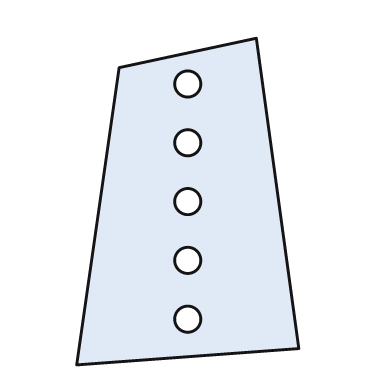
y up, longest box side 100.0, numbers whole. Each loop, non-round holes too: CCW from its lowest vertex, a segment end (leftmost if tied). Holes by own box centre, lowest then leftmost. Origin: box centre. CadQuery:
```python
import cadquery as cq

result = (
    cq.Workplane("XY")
    .moveTo(-34.0, -50.0)
    .lineTo(34.0, -45.0)
    .lineTo(21.0, 50.0)
    .lineTo(-21.0, 41.0)
    .close()
    .moveTo(0.0, -36.0)
    .circle(4.0)
    .moveTo(0.0, -18.0)
    .circle(4.0)
    .moveTo(0.0, 0.0)
    .circle(4.0)
    .moveTo(0.0, 18.0)
    .circle(4.0)
    .moveTo(0.0, 36.0)
    .circle(4.0)
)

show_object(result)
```